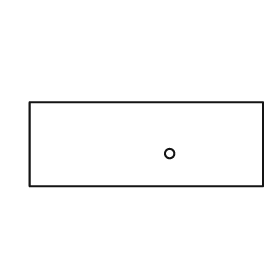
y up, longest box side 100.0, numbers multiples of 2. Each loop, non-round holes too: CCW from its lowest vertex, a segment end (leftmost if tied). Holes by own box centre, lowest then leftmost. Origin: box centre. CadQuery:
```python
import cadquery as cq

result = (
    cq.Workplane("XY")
    .moveTo(-50.0, -18.0)
    .lineTo(50.0, -18.0)
    .lineTo(50.0, 18.0)
    .lineTo(-50.0, 18.0)
    .close()
    .moveTo(10.0, -4.0)
    .circle(2.0)
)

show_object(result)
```